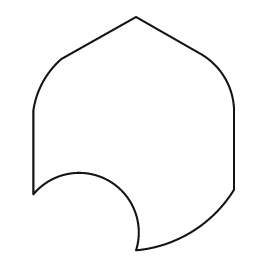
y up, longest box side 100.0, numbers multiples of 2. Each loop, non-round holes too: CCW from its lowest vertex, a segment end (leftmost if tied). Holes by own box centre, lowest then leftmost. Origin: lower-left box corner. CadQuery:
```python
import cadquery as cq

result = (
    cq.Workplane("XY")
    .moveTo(44.0, 0.0)
    .threePointArc((68.0, 8.0), (86.0, 26.0))
    .lineTo(86.0, 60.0)
    .threePointArc((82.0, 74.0), (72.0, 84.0))
    .lineTo(44.0, 100.0)
    .lineTo(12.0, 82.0)
    .threePointArc((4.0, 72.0), (0.0, 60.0))
    .lineTo(0.0, 24.0)
    .threePointArc((32.0, 30.0), (44.0, 0.0))
    .close()
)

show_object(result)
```